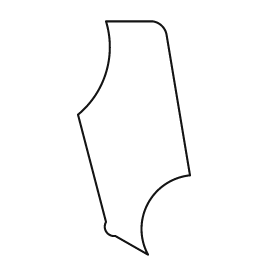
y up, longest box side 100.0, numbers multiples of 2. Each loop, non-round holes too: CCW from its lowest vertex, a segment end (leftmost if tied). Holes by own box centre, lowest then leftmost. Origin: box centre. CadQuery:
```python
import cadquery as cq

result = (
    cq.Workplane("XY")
    .moveTo(6.0, -50.0)
    .threePointArc((6.0, -28.0), (24.0, -16.0))
    .lineTo(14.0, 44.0)
    .threePointArc((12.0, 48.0), (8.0, 50.0))
    .lineTo(-12.0, 50.0)
    .threePointArc((-12.0, 28.0), (-24.0, 10.0))
    .lineTo(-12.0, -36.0)
    .threePointArc((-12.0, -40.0), (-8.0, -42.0))
    .close()
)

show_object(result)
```